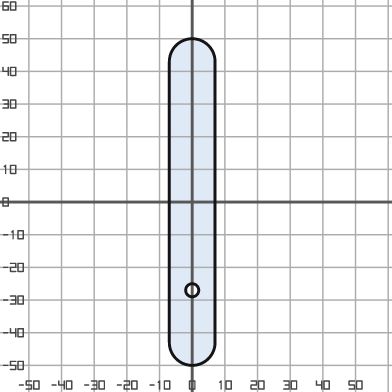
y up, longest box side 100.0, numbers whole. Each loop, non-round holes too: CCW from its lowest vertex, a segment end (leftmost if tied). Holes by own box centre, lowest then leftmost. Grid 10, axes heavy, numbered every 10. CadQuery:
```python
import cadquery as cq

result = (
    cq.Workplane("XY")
    .moveTo(-7.0, -43.0)
    .threePointArc((0.0, -50.0), (7.0, -43.0))
    .lineTo(7.0, 43.0)
    .threePointArc((0.0, 50.0), (-7.0, 43.0))
    .close()
    .moveTo(0.0, -27.0)
    .circle(2.0)
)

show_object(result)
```